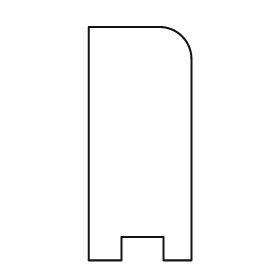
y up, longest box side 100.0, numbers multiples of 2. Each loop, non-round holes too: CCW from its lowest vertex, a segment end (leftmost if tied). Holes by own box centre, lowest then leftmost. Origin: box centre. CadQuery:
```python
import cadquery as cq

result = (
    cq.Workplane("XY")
    .moveTo(-22.0, -50.0)
    .lineTo(-8.0, -50.0)
    .lineTo(-8.0, -40.0)
    .lineTo(10.0, -40.0)
    .lineTo(10.0, -50.0)
    .lineTo(22.0, -50.0)
    .lineTo(22.0, 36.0)
    .threePointArc((18.0, 46.0), (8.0, 50.0))
    .lineTo(-22.0, 50.0)
    .close()
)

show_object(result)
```